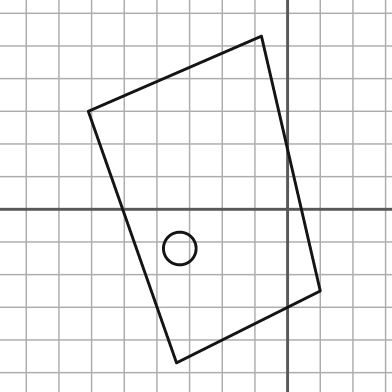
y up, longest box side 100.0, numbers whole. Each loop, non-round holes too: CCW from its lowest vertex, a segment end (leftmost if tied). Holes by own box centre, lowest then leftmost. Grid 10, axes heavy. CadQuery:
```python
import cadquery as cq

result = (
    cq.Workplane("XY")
    .moveTo(-34.0, -47.0)
    .lineTo(10.0, -25.0)
    .lineTo(-8.0, 53.0)
    .lineTo(-61.0, 30.0)
    .close()
    .moveTo(-33.0, -12.0)
    .circle(5.0)
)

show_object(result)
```